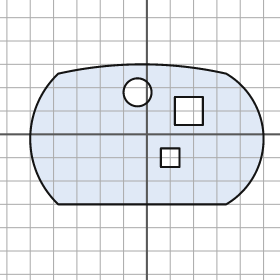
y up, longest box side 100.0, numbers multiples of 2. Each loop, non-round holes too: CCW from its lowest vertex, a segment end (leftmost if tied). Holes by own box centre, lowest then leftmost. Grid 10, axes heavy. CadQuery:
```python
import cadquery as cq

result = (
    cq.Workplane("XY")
    .moveTo(-38.0, -30.0)
    .lineTo(34.0, -30.0)
    .threePointArc((50.0, -2.0), (34.0, 26.0))
    .threePointArc((-2.0, 30.0), (-38.0, 26.0))
    .threePointArc((-50.0, -2.0), (-38.0, -30.0))
    .close()
    .moveTo(6.0, -14.0)
    .lineTo(14.0, -14.0)
    .lineTo(14.0, -6.0)
    .lineTo(6.0, -6.0)
    .close()
    .moveTo(12.0, 4.0)
    .lineTo(24.0, 4.0)
    .lineTo(24.0, 16.0)
    .lineTo(12.0, 16.0)
    .close()
    .moveTo(-4.0, 18.0)
    .circle(6.0)
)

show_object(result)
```